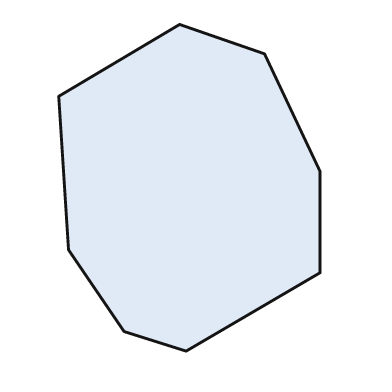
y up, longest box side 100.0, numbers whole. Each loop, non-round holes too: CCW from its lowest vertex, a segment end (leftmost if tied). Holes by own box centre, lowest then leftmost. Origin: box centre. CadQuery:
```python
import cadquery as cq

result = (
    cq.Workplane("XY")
    .moveTo(-1.0, -50.0)
    .lineTo(40.0, -26.0)
    .lineTo(40.0, 5.0)
    .lineTo(23.0, 41.0)
    .lineTo(-3.0, 50.0)
    .lineTo(-40.0, 28.0)
    .lineTo(-37.0, -19.0)
    .lineTo(-20.0, -44.0)
    .close()
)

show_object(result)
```